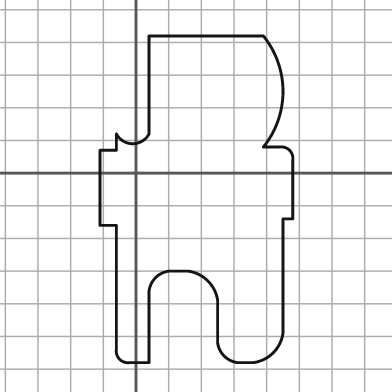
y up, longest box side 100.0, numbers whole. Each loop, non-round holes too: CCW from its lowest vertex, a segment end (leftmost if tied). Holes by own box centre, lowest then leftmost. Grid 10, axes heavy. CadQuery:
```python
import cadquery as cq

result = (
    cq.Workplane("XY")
    .moveTo(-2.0, -58.0)
    .lineTo(4.0, -58.0)
    .lineTo(4.0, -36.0)
    .threePointArc((6.0, -32.0), (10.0, -30.0))
    .lineTo(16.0, -30.0)
    .threePointArc((22.0, -33.0), (25.0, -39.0))
    .lineTo(25.0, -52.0)
    .threePointArc((27.0, -56.0), (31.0, -58.0))
    .lineTo(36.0, -58.0)
    .threePointArc((42.0, -55.0), (45.0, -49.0))
    .lineTo(45.0, -14.0)
    .lineTo(48.0, -14.0)
    .lineTo(48.0, 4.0)
    .threePointArc((47.0, 7.0), (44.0, 8.0))
    .lineTo(39.0, 8.0)
    .threePointArc((45.0, 25.0), (39.0, 42.0))
    .lineTo(4.0, 42.0)
    .lineTo(4.0, 12.0)
    .threePointArc((-1.0, 9.0), (-6.0, 12.0))
    .lineTo(-6.0, 7.0)
    .lineTo(-11.0, 7.0)
    .lineTo(-11.0, -16.0)
    .lineTo(-6.0, -16.0)
    .lineTo(-6.0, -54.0)
    .threePointArc((-5.0, -57.0), (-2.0, -58.0))
    .close()
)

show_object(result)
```